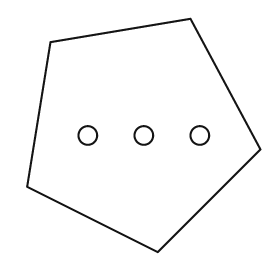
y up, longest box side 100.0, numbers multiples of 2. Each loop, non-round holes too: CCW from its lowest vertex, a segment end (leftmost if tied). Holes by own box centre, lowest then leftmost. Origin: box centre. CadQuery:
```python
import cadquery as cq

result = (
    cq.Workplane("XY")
    .moveTo(6.0, -50.0)
    .lineTo(50.0, -6.0)
    .lineTo(20.0, 50.0)
    .lineTo(-40.0, 40.0)
    .lineTo(-50.0, -22.0)
    .close()
    .moveTo(-24.0, 0.0)
    .circle(4.0)
    .moveTo(0.0, 0.0)
    .circle(4.0)
    .moveTo(24.0, 0.0)
    .circle(4.0)
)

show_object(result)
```